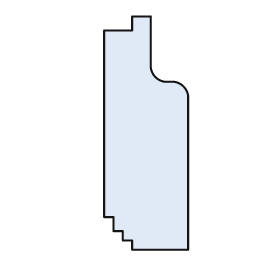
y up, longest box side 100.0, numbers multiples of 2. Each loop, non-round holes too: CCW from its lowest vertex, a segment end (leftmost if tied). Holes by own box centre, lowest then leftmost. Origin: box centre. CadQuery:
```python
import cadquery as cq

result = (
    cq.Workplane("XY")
    .moveTo(-6.0, -50.0)
    .lineTo(18.0, -50.0)
    .lineTo(18.0, 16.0)
    .threePointArc((16.0, 20.0), (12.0, 22.0))
    .lineTo(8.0, 22.0)
    .threePointArc((4.0, 24.0), (2.0, 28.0))
    .lineTo(2.0, 50.0)
    .lineTo(-6.0, 50.0)
    .lineTo(-6.0, 44.0)
    .lineTo(-18.0, 44.0)
    .lineTo(-18.0, -36.0)
    .lineTo(-14.0, -36.0)
    .lineTo(-14.0, -42.0)
    .lineTo(-10.0, -42.0)
    .lineTo(-10.0, -46.0)
    .lineTo(-6.0, -46.0)
    .close()
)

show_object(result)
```